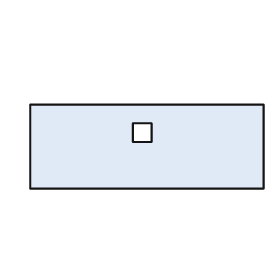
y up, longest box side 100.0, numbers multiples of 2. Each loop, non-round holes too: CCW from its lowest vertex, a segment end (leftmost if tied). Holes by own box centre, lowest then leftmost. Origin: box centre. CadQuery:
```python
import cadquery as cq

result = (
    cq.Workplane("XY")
    .moveTo(-50.0, -18.0)
    .lineTo(50.0, -18.0)
    .lineTo(50.0, 18.0)
    .lineTo(-50.0, 18.0)
    .close()
    .moveTo(-6.0, 2.0)
    .lineTo(2.0, 2.0)
    .lineTo(2.0, 10.0)
    .lineTo(-6.0, 10.0)
    .close()
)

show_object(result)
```